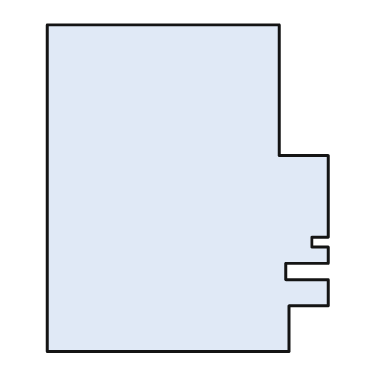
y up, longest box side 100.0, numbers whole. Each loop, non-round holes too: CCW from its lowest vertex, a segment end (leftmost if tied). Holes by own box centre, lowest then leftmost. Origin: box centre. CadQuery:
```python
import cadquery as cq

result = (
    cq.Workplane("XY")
    .moveTo(-43.0, -50.0)
    .lineTo(31.0, -50.0)
    .lineTo(31.0, -36.0)
    .lineTo(43.0, -36.0)
    .lineTo(43.0, -28.0)
    .lineTo(30.0, -28.0)
    .lineTo(30.0, -23.0)
    .lineTo(43.0, -23.0)
    .lineTo(43.0, -18.0)
    .lineTo(38.0, -18.0)
    .lineTo(38.0, -15.0)
    .lineTo(43.0, -15.0)
    .lineTo(43.0, 10.0)
    .lineTo(28.0, 10.0)
    .lineTo(28.0, 50.0)
    .lineTo(-43.0, 50.0)
    .close()
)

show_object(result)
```